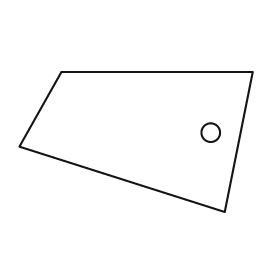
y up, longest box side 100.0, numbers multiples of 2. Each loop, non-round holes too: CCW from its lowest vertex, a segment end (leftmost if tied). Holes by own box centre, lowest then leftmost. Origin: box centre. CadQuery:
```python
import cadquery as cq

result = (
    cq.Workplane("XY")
    .moveTo(38.0, -30.0)
    .lineTo(50.0, 30.0)
    .lineTo(-32.0, 30.0)
    .lineTo(-50.0, -2.0)
    .close()
    .moveTo(32.0, 4.0)
    .circle(4.0)
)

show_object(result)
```